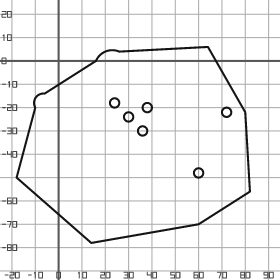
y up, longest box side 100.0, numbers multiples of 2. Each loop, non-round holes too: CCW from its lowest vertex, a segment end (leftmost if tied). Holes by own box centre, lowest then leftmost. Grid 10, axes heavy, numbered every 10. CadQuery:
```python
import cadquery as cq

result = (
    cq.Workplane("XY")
    .moveTo(14.0, -78.0)
    .lineTo(60.0, -70.0)
    .lineTo(82.0, -56.0)
    .lineTo(80.0, -22.0)
    .lineTo(64.0, 6.0)
    .lineTo(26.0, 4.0)
    .threePointArc((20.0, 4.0), (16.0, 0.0))
    .lineTo(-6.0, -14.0)
    .threePointArc((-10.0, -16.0), (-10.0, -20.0))
    .lineTo(-18.0, -50.0)
    .close()
    .moveTo(60.0, -48.0)
    .circle(2.0)
    .moveTo(36.0, -30.0)
    .circle(2.0)
    .moveTo(30.0, -24.0)
    .circle(2.0)
    .moveTo(72.0, -22.0)
    .circle(2.0)
    .moveTo(38.0, -20.0)
    .circle(2.0)
    .moveTo(24.0, -18.0)
    .circle(2.0)
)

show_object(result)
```